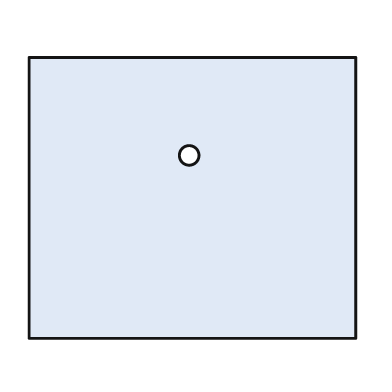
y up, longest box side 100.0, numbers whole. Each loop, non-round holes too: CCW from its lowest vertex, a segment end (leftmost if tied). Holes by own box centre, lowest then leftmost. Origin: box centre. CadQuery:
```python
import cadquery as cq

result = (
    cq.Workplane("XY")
    .moveTo(-50.0, -43.0)
    .lineTo(50.0, -43.0)
    .lineTo(50.0, 43.0)
    .lineTo(-50.0, 43.0)
    .close()
    .moveTo(-1.0, 13.0)
    .circle(3.0)
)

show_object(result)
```